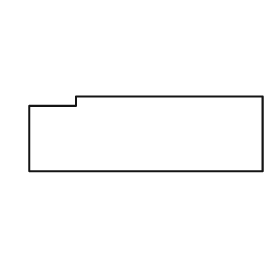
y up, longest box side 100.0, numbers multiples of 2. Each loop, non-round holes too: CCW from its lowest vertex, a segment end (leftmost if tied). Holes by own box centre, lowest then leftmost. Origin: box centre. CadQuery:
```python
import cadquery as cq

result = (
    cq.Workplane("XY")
    .moveTo(-50.0, -16.0)
    .lineTo(50.0, -16.0)
    .lineTo(50.0, 16.0)
    .lineTo(-30.0, 16.0)
    .lineTo(-30.0, 12.0)
    .lineTo(-50.0, 12.0)
    .close()
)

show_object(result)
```